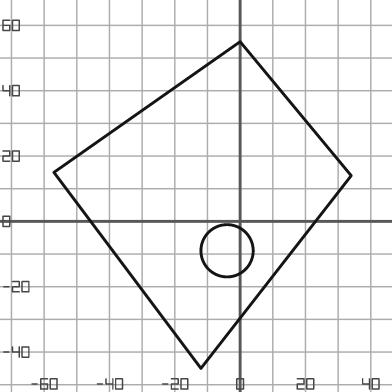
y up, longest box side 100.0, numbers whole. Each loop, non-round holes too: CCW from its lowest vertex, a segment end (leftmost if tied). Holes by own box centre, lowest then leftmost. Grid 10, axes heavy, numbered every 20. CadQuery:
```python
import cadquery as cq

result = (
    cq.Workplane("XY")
    .moveTo(-12.0, -45.0)
    .lineTo(34.0, 14.0)
    .lineTo(0.0, 55.0)
    .lineTo(-57.0, 15.0)
    .close()
    .moveTo(-4.0, -9.0)
    .circle(8.0)
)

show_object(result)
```